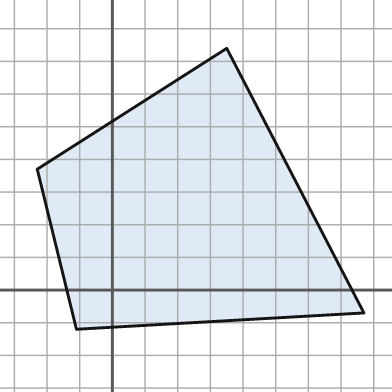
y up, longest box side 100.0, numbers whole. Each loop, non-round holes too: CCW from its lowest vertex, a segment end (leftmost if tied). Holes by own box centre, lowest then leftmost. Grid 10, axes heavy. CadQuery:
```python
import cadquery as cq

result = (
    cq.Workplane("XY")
    .moveTo(-11.0, -12.0)
    .lineTo(77.0, -7.0)
    .lineTo(35.0, 74.0)
    .lineTo(-23.0, 37.0)
    .close()
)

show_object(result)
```